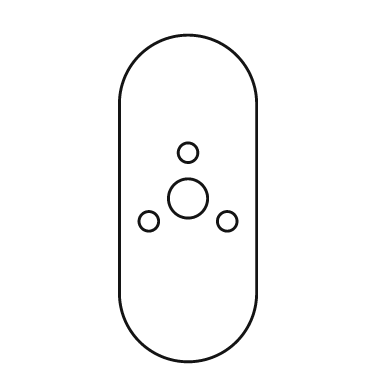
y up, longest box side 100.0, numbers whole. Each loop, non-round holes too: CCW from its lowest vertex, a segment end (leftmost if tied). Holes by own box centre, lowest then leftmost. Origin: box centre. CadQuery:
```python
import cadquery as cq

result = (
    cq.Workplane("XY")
    .moveTo(-21.0, -29.0)
    .threePointArc((0.0, -50.0), (21.0, -29.0))
    .lineTo(21.0, 29.0)
    .threePointArc((0.0, 50.0), (-21.0, 29.0))
    .close()
    .moveTo(-12.0, -7.0)
    .circle(3.0)
    .moveTo(12.0, -7.0)
    .circle(3.0)
    .moveTo(0.0, 0.0)
    .circle(6.0)
    .moveTo(0.0, 14.0)
    .circle(3.0)
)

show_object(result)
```